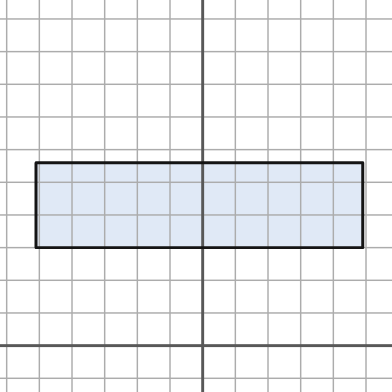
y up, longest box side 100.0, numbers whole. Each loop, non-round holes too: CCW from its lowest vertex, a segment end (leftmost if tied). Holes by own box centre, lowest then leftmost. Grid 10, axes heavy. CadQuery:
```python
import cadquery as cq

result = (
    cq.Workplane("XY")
    .moveTo(-51.0, 30.0)
    .lineTo(49.0, 30.0)
    .lineTo(49.0, 56.0)
    .lineTo(-51.0, 56.0)
    .close()
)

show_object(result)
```